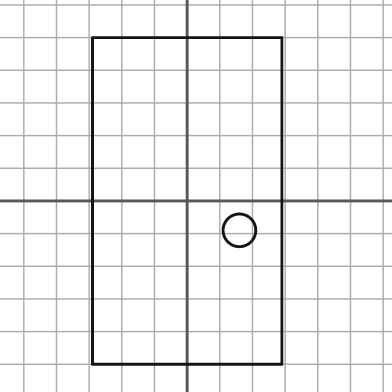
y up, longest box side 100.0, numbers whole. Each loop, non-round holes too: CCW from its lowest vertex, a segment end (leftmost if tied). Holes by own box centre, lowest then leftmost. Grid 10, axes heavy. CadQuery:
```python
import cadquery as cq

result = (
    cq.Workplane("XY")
    .moveTo(-29.0, -50.0)
    .lineTo(29.0, -50.0)
    .lineTo(29.0, 50.0)
    .lineTo(-29.0, 50.0)
    .close()
    .moveTo(16.0, -9.0)
    .circle(5.0)
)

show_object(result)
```